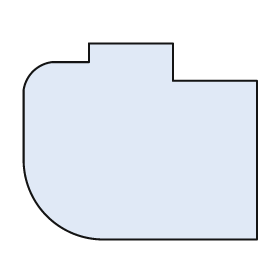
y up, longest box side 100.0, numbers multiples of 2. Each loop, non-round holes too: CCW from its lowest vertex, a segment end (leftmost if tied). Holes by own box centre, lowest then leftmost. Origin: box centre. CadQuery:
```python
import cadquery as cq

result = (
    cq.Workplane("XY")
    .moveTo(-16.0, -42.0)
    .lineTo(50.0, -42.0)
    .lineTo(50.0, 26.0)
    .lineTo(14.0, 26.0)
    .lineTo(14.0, 42.0)
    .lineTo(-22.0, 42.0)
    .lineTo(-22.0, 34.0)
    .lineTo(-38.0, 34.0)
    .threePointArc((-46.0, 30.0), (-50.0, 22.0))
    .lineTo(-50.0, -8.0)
    .threePointArc((-40.0, -32.0), (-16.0, -42.0))
    .close()
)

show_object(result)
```